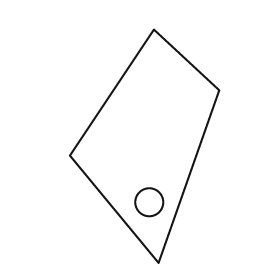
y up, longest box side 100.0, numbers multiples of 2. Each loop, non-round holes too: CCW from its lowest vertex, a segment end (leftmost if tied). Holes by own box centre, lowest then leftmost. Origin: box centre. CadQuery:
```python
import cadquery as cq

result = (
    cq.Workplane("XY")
    .moveTo(6.0, -50.0)
    .lineTo(32.0, 24.0)
    .lineTo(4.0, 50.0)
    .lineTo(-32.0, -4.0)
    .close()
    .moveTo(2.0, -24.0)
    .circle(6.0)
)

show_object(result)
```